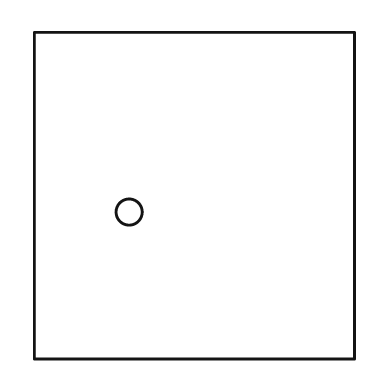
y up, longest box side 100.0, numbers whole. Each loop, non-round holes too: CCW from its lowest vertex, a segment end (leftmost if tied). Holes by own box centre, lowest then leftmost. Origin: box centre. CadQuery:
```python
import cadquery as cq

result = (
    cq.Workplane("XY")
    .moveTo(-49.0, -50.0)
    .lineTo(49.0, -50.0)
    .lineTo(49.0, 50.0)
    .lineTo(-49.0, 50.0)
    .close()
    .moveTo(-20.0, -5.0)
    .circle(4.0)
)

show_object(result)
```